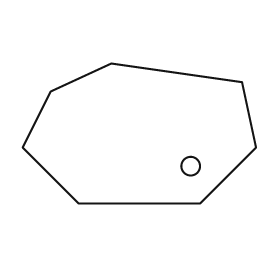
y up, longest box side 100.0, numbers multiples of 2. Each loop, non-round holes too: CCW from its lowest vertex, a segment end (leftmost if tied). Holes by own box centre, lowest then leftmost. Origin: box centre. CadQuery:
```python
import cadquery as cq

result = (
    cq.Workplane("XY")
    .moveTo(-26.0, -30.0)
    .lineTo(26.0, -30.0)
    .lineTo(50.0, -6.0)
    .lineTo(44.0, 22.0)
    .lineTo(-12.0, 30.0)
    .lineTo(-38.0, 18.0)
    .lineTo(-50.0, -6.0)
    .close()
    .moveTo(22.0, -14.0)
    .circle(4.0)
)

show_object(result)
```